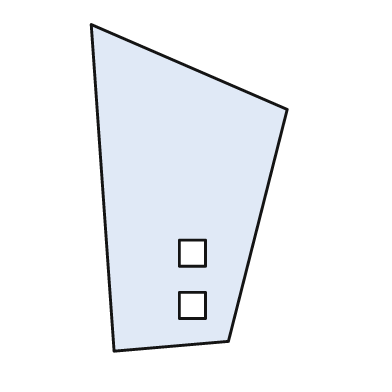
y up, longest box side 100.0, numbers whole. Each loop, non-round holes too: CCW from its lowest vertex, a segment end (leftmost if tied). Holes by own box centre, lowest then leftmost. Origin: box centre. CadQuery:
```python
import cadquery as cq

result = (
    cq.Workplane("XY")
    .moveTo(-23.0, -50.0)
    .lineTo(12.0, -47.0)
    .lineTo(30.0, 24.0)
    .lineTo(-30.0, 50.0)
    .close()
    .moveTo(-3.0, -40.0)
    .lineTo(5.0, -40.0)
    .lineTo(5.0, -32.0)
    .lineTo(-3.0, -32.0)
    .close()
    .moveTo(-3.0, -24.0)
    .lineTo(5.0, -24.0)
    .lineTo(5.0, -16.0)
    .lineTo(-3.0, -16.0)
    .close()
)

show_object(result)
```